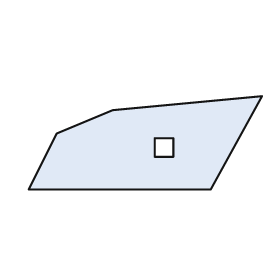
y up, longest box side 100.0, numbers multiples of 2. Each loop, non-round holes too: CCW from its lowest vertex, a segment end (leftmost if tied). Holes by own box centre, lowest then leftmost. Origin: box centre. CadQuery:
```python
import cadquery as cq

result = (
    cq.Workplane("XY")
    .moveTo(-50.0, -20.0)
    .lineTo(28.0, -20.0)
    .lineTo(50.0, 20.0)
    .lineTo(-14.0, 14.0)
    .lineTo(-38.0, 4.0)
    .close()
    .moveTo(4.0, -6.0)
    .lineTo(12.0, -6.0)
    .lineTo(12.0, 2.0)
    .lineTo(4.0, 2.0)
    .close()
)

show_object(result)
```